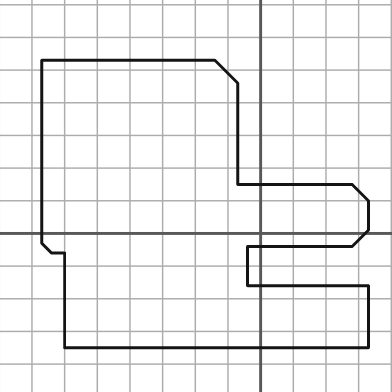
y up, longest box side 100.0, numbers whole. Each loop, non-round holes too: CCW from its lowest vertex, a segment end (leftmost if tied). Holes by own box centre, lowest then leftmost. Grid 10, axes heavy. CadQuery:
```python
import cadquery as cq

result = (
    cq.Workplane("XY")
    .moveTo(-60.0, -35.0)
    .lineTo(33.0, -35.0)
    .lineTo(33.0, -16.0)
    .lineTo(-4.0, -16.0)
    .lineTo(-4.0, -4.0)
    .lineTo(28.0, -4.0)
    .lineTo(33.0, 1.0)
    .lineTo(33.0, 10.0)
    .lineTo(28.0, 15.0)
    .lineTo(-7.0, 15.0)
    .lineTo(-7.0, 46.0)
    .lineTo(-14.0, 53.0)
    .lineTo(-67.0, 53.0)
    .lineTo(-67.0, -3.0)
    .lineTo(-64.0, -6.0)
    .lineTo(-60.0, -6.0)
    .close()
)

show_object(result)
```